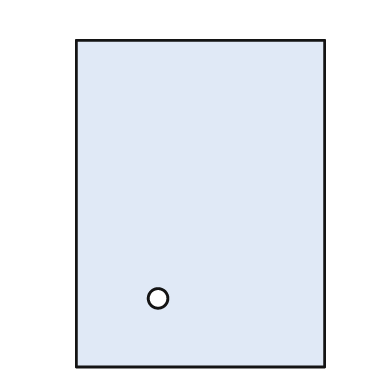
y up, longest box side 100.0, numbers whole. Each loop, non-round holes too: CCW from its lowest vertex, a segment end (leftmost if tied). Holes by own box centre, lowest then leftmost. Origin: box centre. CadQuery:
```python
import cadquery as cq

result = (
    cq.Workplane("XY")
    .moveTo(-38.0, -50.0)
    .lineTo(38.0, -50.0)
    .lineTo(38.0, 50.0)
    .lineTo(-38.0, 50.0)
    .close()
    .moveTo(-13.0, -29.0)
    .circle(3.0)
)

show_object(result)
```